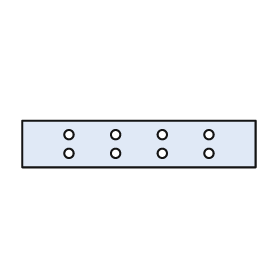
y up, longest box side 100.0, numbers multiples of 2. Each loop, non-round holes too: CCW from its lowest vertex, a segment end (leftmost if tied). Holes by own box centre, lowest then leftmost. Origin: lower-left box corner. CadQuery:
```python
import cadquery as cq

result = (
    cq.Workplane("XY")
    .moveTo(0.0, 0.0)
    .lineTo(100.0, 0.0)
    .lineTo(100.0, 20.0)
    .lineTo(0.0, 20.0)
    .close()
    .moveTo(20.0, 6.0)
    .circle(2.0)
    .moveTo(40.0, 6.0)
    .circle(2.0)
    .moveTo(60.0, 6.0)
    .circle(2.0)
    .moveTo(80.0, 6.0)
    .circle(2.0)
    .moveTo(20.0, 14.0)
    .circle(2.0)
    .moveTo(40.0, 14.0)
    .circle(2.0)
    .moveTo(60.0, 14.0)
    .circle(2.0)
    .moveTo(80.0, 14.0)
    .circle(2.0)
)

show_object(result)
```